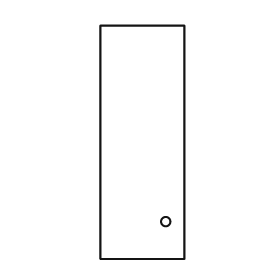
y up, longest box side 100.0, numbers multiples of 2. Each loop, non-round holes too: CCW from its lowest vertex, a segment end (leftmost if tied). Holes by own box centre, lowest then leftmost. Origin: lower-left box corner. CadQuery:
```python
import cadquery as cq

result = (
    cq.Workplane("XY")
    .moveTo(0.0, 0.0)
    .lineTo(36.0, 0.0)
    .lineTo(36.0, 100.0)
    .lineTo(0.0, 100.0)
    .close()
    .moveTo(28.0, 16.0)
    .circle(2.0)
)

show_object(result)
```